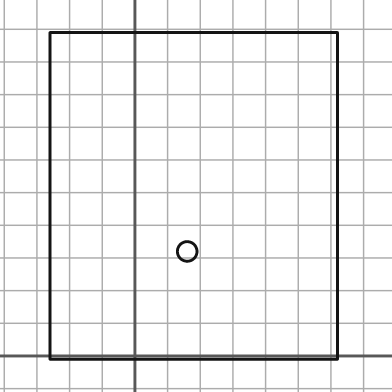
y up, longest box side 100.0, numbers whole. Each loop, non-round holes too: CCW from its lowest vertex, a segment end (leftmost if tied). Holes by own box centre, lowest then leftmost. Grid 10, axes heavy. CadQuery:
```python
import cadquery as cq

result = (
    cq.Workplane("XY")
    .moveTo(-26.0, -1.0)
    .lineTo(62.0, -1.0)
    .lineTo(62.0, 99.0)
    .lineTo(-26.0, 99.0)
    .close()
    .moveTo(16.0, 32.0)
    .circle(3.0)
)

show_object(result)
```